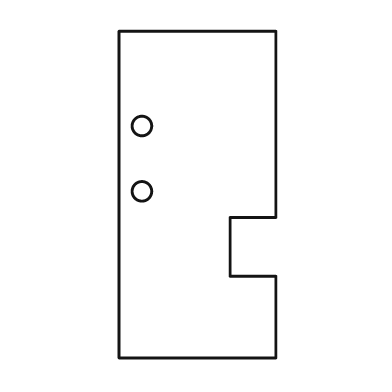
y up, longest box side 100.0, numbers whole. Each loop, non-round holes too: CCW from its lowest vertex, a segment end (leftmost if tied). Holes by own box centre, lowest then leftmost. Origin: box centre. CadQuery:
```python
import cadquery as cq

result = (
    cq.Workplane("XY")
    .moveTo(-24.0, -50.0)
    .lineTo(24.0, -50.0)
    .lineTo(24.0, -25.0)
    .lineTo(10.0, -25.0)
    .lineTo(10.0, -7.0)
    .lineTo(24.0, -7.0)
    .lineTo(24.0, 50.0)
    .lineTo(-24.0, 50.0)
    .close()
    .moveTo(-17.0, 1.0)
    .circle(3.0)
    .moveTo(-17.0, 21.0)
    .circle(3.0)
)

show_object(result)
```